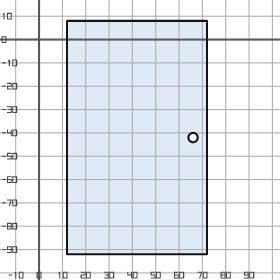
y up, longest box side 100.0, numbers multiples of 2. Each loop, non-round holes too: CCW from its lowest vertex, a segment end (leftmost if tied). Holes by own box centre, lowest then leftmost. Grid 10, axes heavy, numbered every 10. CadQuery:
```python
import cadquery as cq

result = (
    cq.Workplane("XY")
    .moveTo(12.0, -92.0)
    .lineTo(72.0, -92.0)
    .lineTo(72.0, 8.0)
    .lineTo(12.0, 8.0)
    .close()
    .moveTo(66.0, -42.0)
    .circle(2.0)
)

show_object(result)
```